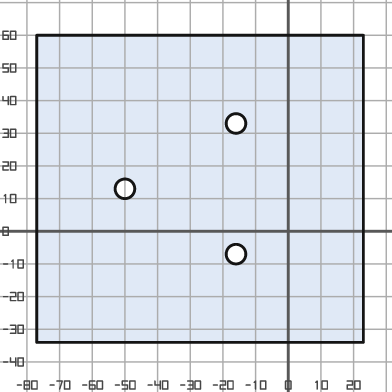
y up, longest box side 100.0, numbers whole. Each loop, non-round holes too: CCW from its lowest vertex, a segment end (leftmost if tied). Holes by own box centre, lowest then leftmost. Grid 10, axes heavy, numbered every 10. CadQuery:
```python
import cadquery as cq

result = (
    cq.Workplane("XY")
    .moveTo(-77.0, -34.0)
    .lineTo(23.0, -34.0)
    .lineTo(23.0, 60.0)
    .lineTo(-77.0, 60.0)
    .close()
    .moveTo(-16.0, -7.0)
    .circle(3.0)
    .moveTo(-50.0, 13.0)
    .circle(3.0)
    .moveTo(-16.0, 33.0)
    .circle(3.0)
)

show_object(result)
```